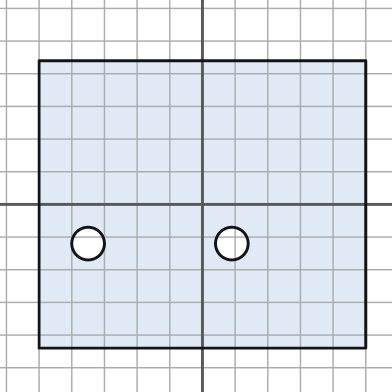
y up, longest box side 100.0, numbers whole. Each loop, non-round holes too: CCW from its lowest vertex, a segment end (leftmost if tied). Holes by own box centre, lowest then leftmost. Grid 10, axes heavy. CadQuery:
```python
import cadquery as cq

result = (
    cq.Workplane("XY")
    .moveTo(-50.0, -44.0)
    .lineTo(50.0, -44.0)
    .lineTo(50.0, 44.0)
    .lineTo(-50.0, 44.0)
    .close()
    .moveTo(-35.0, -12.0)
    .circle(5.0)
    .moveTo(9.0, -12.0)
    .circle(5.0)
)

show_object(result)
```